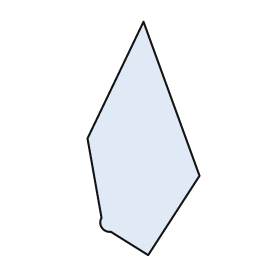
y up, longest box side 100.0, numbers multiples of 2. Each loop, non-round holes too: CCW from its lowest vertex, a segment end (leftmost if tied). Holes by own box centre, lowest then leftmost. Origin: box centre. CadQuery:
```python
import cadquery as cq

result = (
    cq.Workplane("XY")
    .moveTo(2.0, -50.0)
    .lineTo(24.0, -16.0)
    .lineTo(0.0, 50.0)
    .lineTo(-24.0, 0.0)
    .lineTo(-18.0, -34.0)
    .threePointArc((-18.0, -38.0), (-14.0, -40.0))
    .close()
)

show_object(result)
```